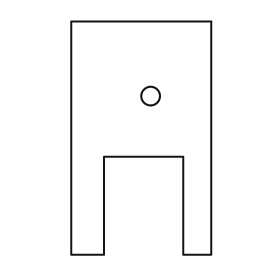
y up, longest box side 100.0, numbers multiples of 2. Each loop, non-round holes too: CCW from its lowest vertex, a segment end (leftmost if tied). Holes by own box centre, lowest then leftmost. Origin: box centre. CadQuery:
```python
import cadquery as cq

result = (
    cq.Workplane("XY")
    .moveTo(-30.0, -50.0)
    .lineTo(-16.0, -50.0)
    .lineTo(-16.0, -8.0)
    .lineTo(18.0, -8.0)
    .lineTo(18.0, -50.0)
    .lineTo(30.0, -50.0)
    .lineTo(30.0, 50.0)
    .lineTo(-30.0, 50.0)
    .close()
    .moveTo(4.0, 18.0)
    .circle(4.0)
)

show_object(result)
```